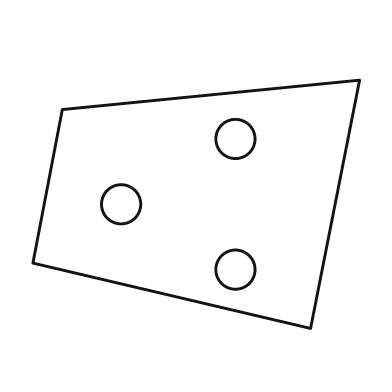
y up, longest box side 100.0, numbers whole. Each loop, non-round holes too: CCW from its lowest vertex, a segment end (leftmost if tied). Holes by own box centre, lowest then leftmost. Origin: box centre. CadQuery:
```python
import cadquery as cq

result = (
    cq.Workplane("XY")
    .moveTo(35.0, -38.0)
    .lineTo(50.0, 38.0)
    .lineTo(-41.0, 29.0)
    .lineTo(-50.0, -18.0)
    .close()
    .moveTo(12.0, -20.0)
    .circle(6.0)
    .moveTo(-23.0, 0.0)
    .circle(6.0)
    .moveTo(12.0, 20.0)
    .circle(6.0)
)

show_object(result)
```